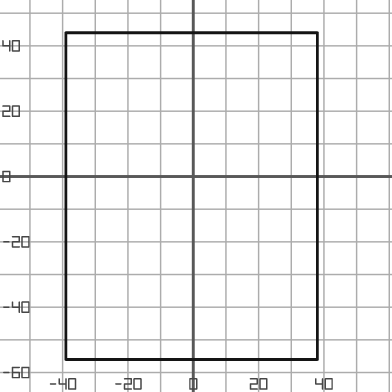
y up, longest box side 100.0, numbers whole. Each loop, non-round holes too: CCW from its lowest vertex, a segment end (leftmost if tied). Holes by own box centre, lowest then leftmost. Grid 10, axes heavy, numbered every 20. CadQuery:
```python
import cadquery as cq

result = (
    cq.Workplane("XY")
    .moveTo(-39.0, -56.0)
    .lineTo(38.0, -56.0)
    .lineTo(38.0, 44.0)
    .lineTo(-39.0, 44.0)
    .close()
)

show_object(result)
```